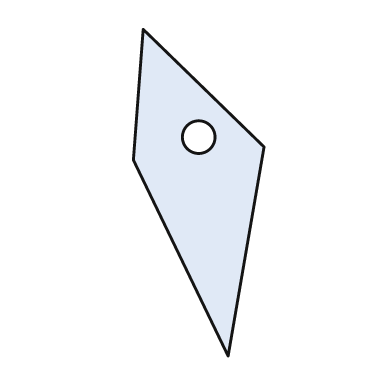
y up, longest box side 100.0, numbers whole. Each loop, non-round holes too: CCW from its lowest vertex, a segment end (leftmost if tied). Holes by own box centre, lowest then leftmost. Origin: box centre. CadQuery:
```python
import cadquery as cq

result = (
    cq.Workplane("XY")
    .moveTo(9.0, -50.0)
    .lineTo(20.0, 14.0)
    .lineTo(-17.0, 50.0)
    .lineTo(-20.0, 10.0)
    .close()
    .moveTo(0.0, 17.0)
    .circle(5.0)
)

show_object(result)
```